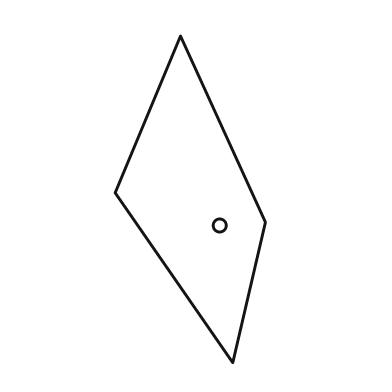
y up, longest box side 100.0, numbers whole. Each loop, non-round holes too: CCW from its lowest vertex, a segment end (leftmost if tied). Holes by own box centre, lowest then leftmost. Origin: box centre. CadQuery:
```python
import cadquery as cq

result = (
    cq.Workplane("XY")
    .moveTo(13.0, -50.0)
    .lineTo(23.0, -7.0)
    .lineTo(-3.0, 50.0)
    .lineTo(-23.0, 2.0)
    .close()
    .moveTo(9.0, -8.0)
    .circle(2.0)
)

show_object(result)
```